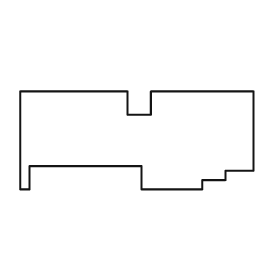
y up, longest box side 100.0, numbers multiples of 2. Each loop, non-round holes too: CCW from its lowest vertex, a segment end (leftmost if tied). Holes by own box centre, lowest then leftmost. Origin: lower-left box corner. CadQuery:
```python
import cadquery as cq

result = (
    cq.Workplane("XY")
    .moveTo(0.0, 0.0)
    .lineTo(4.0, 0.0)
    .lineTo(4.0, 10.0)
    .lineTo(52.0, 10.0)
    .lineTo(52.0, 0.0)
    .lineTo(78.0, 0.0)
    .lineTo(78.0, 4.0)
    .lineTo(88.0, 4.0)
    .lineTo(88.0, 8.0)
    .lineTo(100.0, 8.0)
    .lineTo(100.0, 42.0)
    .lineTo(56.0, 42.0)
    .lineTo(56.0, 32.0)
    .lineTo(46.0, 32.0)
    .lineTo(46.0, 42.0)
    .lineTo(0.0, 42.0)
    .close()
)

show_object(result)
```